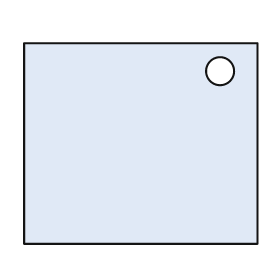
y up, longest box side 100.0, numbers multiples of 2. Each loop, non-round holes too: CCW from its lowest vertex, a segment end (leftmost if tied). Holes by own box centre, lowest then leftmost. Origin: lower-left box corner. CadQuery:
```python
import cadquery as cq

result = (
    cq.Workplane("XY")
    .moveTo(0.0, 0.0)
    .lineTo(100.0, 0.0)
    .lineTo(100.0, 86.0)
    .lineTo(0.0, 86.0)
    .close()
    .moveTo(84.0, 74.0)
    .circle(6.0)
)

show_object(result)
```